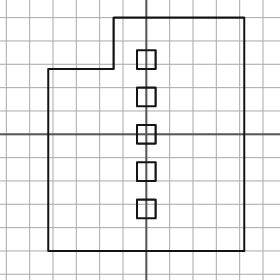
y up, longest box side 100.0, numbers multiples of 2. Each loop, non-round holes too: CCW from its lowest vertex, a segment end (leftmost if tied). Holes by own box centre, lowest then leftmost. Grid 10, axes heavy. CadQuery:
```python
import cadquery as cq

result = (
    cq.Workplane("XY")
    .moveTo(-42.0, -50.0)
    .lineTo(42.0, -50.0)
    .lineTo(42.0, 50.0)
    .lineTo(-14.0, 50.0)
    .lineTo(-14.0, 28.0)
    .lineTo(-42.0, 28.0)
    .close()
    .moveTo(-4.0, -36.0)
    .lineTo(4.0, -36.0)
    .lineTo(4.0, -28.0)
    .lineTo(-4.0, -28.0)
    .close()
    .moveTo(-4.0, -20.0)
    .lineTo(4.0, -20.0)
    .lineTo(4.0, -12.0)
    .lineTo(-4.0, -12.0)
    .close()
    .moveTo(-4.0, -4.0)
    .lineTo(4.0, -4.0)
    .lineTo(4.0, 4.0)
    .lineTo(-4.0, 4.0)
    .close()
    .moveTo(-4.0, 12.0)
    .lineTo(4.0, 12.0)
    .lineTo(4.0, 20.0)
    .lineTo(-4.0, 20.0)
    .close()
    .moveTo(-4.0, 28.0)
    .lineTo(4.0, 28.0)
    .lineTo(4.0, 36.0)
    .lineTo(-4.0, 36.0)
    .close()
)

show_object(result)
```